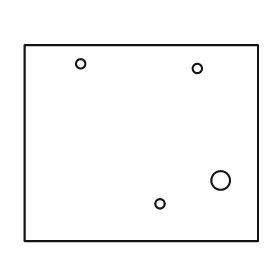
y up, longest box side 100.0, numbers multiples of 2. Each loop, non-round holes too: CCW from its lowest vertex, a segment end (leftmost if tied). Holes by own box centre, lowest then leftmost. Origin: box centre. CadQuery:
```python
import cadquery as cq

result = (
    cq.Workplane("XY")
    .moveTo(-50.0, -42.0)
    .lineTo(50.0, -42.0)
    .lineTo(50.0, 42.0)
    .lineTo(-50.0, 42.0)
    .close()
    .moveTo(8.0, -26.0)
    .circle(2.0)
    .moveTo(34.0, -16.0)
    .circle(4.0)
    .moveTo(24.0, 32.0)
    .circle(2.0)
    .moveTo(-26.0, 34.0)
    .circle(2.0)
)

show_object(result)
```